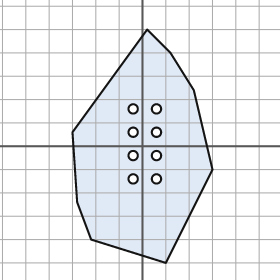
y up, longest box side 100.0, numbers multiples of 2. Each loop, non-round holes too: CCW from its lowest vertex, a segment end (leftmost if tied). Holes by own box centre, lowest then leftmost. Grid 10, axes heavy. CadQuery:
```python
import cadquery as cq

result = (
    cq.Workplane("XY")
    .moveTo(10.0, -50.0)
    .lineTo(30.0, -10.0)
    .lineTo(22.0, 24.0)
    .lineTo(12.0, 40.0)
    .lineTo(2.0, 50.0)
    .lineTo(-30.0, 6.0)
    .lineTo(-28.0, -24.0)
    .lineTo(-22.0, -40.0)
    .close()
    .moveTo(-4.0, -14.0)
    .circle(2.0)
    .moveTo(6.0, -14.0)
    .circle(2.0)
    .moveTo(-4.0, -4.0)
    .circle(2.0)
    .moveTo(6.0, -4.0)
    .circle(2.0)
    .moveTo(-4.0, 6.0)
    .circle(2.0)
    .moveTo(6.0, 6.0)
    .circle(2.0)
    .moveTo(-4.0, 16.0)
    .circle(2.0)
    .moveTo(6.0, 16.0)
    .circle(2.0)
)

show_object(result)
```